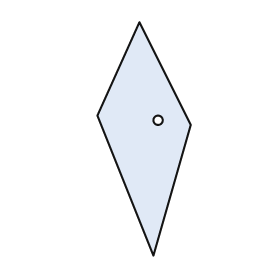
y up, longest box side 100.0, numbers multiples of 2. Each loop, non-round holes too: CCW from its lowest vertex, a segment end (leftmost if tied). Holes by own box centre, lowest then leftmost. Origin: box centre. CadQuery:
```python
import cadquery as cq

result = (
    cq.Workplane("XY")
    .moveTo(4.0, -50.0)
    .lineTo(20.0, 6.0)
    .lineTo(-2.0, 50.0)
    .lineTo(-20.0, 10.0)
    .close()
    .moveTo(6.0, 8.0)
    .circle(2.0)
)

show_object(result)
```